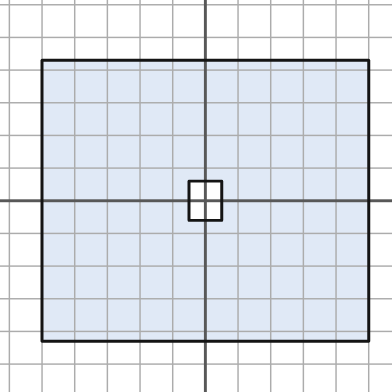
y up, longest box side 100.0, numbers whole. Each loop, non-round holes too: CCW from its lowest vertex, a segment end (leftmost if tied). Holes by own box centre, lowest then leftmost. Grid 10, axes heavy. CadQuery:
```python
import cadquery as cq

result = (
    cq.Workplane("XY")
    .moveTo(-50.0, -43.0)
    .lineTo(50.0, -43.0)
    .lineTo(50.0, 43.0)
    .lineTo(-50.0, 43.0)
    .close()
    .moveTo(-5.0, -6.0)
    .lineTo(5.0, -6.0)
    .lineTo(5.0, 6.0)
    .lineTo(-5.0, 6.0)
    .close()
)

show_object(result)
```